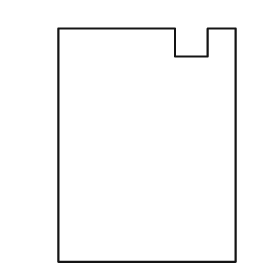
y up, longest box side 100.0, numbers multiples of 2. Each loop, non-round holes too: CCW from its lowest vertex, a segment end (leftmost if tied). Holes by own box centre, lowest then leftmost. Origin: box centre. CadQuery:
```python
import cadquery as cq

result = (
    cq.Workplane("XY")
    .moveTo(-38.0, -50.0)
    .lineTo(38.0, -50.0)
    .lineTo(38.0, 50.0)
    .lineTo(26.0, 50.0)
    .lineTo(26.0, 38.0)
    .lineTo(12.0, 38.0)
    .lineTo(12.0, 50.0)
    .lineTo(-38.0, 50.0)
    .close()
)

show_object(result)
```